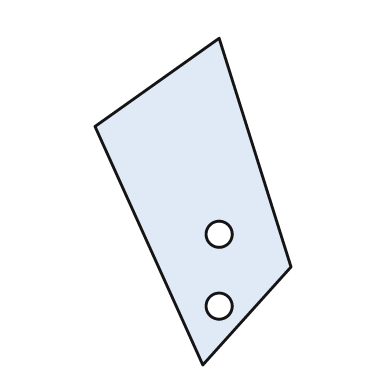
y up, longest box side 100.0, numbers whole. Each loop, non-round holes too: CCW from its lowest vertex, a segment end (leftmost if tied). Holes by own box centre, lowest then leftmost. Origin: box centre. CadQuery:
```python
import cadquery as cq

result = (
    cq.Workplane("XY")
    .moveTo(3.0, -50.0)
    .lineTo(30.0, -20.0)
    .lineTo(8.0, 50.0)
    .lineTo(-30.0, 23.0)
    .close()
    .moveTo(8.0, -32.0)
    .circle(4.0)
    .moveTo(8.0, -10.0)
    .circle(4.0)
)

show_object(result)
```